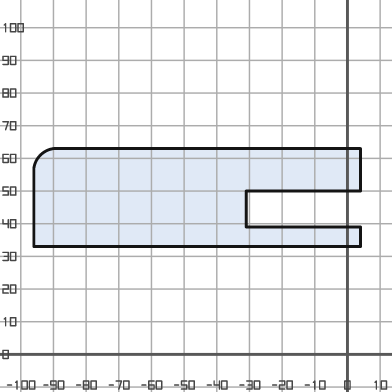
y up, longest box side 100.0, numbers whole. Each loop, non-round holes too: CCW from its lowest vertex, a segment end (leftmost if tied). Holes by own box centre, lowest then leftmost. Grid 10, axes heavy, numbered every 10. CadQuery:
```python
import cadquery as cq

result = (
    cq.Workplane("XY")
    .moveTo(-96.0, 33.0)
    .lineTo(4.0, 33.0)
    .lineTo(4.0, 39.0)
    .lineTo(-31.0, 39.0)
    .lineTo(-31.0, 50.0)
    .lineTo(4.0, 50.0)
    .lineTo(4.0, 63.0)
    .lineTo(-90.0, 63.0)
    .threePointArc((-94.0, 61.0), (-96.0, 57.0))
    .close()
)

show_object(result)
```